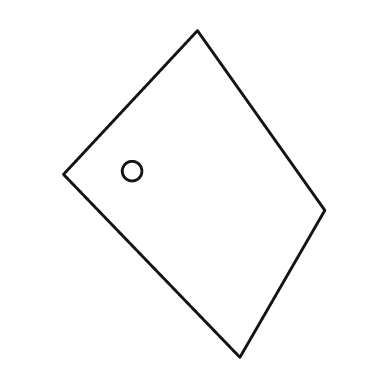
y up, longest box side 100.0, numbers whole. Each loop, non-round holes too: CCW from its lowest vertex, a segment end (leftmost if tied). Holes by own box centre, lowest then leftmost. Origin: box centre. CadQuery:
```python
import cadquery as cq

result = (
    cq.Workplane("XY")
    .moveTo(14.0, -50.0)
    .lineTo(40.0, -5.0)
    .lineTo(1.0, 50.0)
    .lineTo(-40.0, 6.0)
    .close()
    .moveTo(-19.0, 7.0)
    .circle(3.0)
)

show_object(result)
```